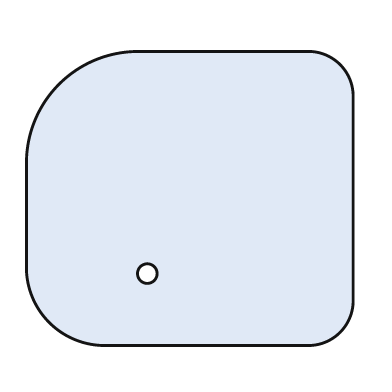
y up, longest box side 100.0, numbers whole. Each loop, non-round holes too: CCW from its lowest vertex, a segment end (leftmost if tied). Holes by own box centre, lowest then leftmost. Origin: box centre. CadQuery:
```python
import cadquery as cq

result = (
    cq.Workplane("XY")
    .moveTo(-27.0, -45.0)
    .lineTo(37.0, -45.0)
    .threePointArc((46.0, -41.0), (50.0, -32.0))
    .lineTo(50.0, 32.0)
    .threePointArc((46.0, 41.0), (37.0, 45.0))
    .lineTo(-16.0, 45.0)
    .threePointArc((-40.0, 35.0), (-50.0, 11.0))
    .lineTo(-50.0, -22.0)
    .threePointArc((-43.0, -38.0), (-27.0, -45.0))
    .close()
    .moveTo(-13.0, -23.0)
    .circle(3.0)
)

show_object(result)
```